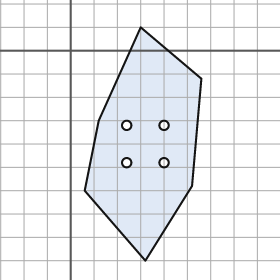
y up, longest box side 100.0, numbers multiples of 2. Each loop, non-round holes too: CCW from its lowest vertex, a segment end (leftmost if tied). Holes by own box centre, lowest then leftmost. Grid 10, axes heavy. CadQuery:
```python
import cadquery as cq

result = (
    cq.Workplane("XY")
    .moveTo(32.0, -90.0)
    .lineTo(52.0, -58.0)
    .lineTo(56.0, -12.0)
    .lineTo(30.0, 10.0)
    .lineTo(12.0, -30.0)
    .lineTo(6.0, -60.0)
    .close()
    .moveTo(24.0, -48.0)
    .circle(2.0)
    .moveTo(40.0, -48.0)
    .circle(2.0)
    .moveTo(24.0, -32.0)
    .circle(2.0)
    .moveTo(40.0, -32.0)
    .circle(2.0)
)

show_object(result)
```